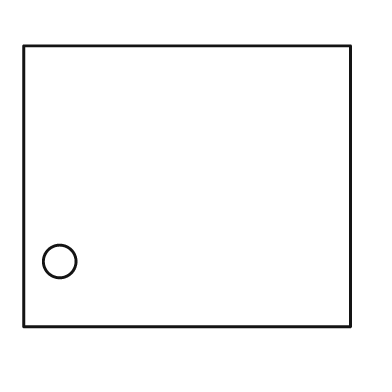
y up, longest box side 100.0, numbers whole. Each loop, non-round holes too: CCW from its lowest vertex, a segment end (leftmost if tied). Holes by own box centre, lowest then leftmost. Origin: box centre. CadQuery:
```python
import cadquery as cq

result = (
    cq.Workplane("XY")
    .moveTo(-50.0, -43.0)
    .lineTo(50.0, -43.0)
    .lineTo(50.0, 43.0)
    .lineTo(-50.0, 43.0)
    .close()
    .moveTo(-39.0, -23.0)
    .circle(5.0)
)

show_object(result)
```